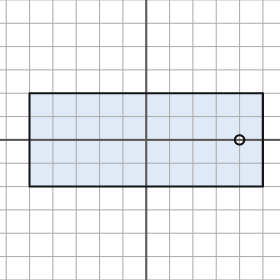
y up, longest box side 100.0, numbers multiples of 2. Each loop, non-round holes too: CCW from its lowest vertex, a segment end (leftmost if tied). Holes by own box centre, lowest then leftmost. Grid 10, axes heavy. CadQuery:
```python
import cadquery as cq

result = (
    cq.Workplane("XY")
    .moveTo(-50.0, -20.0)
    .lineTo(50.0, -20.0)
    .lineTo(50.0, 20.0)
    .lineTo(-50.0, 20.0)
    .close()
    .moveTo(40.0, 0.0)
    .circle(2.0)
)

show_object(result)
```